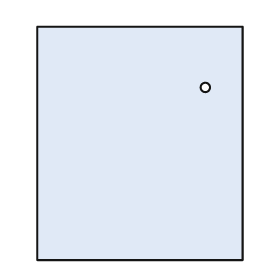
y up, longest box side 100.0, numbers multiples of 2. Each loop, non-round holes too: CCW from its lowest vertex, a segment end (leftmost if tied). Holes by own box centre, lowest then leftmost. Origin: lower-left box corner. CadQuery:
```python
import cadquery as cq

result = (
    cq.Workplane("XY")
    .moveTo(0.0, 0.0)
    .lineTo(88.0, 0.0)
    .lineTo(88.0, 100.0)
    .lineTo(0.0, 100.0)
    .close()
    .moveTo(72.0, 74.0)
    .circle(2.0)
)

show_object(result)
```